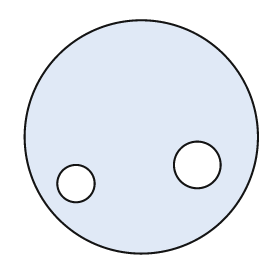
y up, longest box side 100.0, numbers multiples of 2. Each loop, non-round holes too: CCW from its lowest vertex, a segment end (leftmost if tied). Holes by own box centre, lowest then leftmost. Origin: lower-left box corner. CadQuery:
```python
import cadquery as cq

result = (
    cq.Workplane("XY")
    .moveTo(50.0, 50.0)
    .circle(50.0)
    .moveTo(22.0, 30.0)
    .circle(8.0)
    .moveTo(74.0, 38.0)
    .circle(10.0)
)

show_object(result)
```